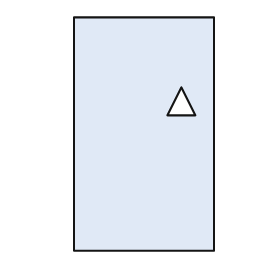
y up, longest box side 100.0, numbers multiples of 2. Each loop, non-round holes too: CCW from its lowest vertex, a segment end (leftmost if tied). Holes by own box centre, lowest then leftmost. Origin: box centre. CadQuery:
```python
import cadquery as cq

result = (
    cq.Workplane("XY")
    .moveTo(-30.0, -50.0)
    .lineTo(30.0, -50.0)
    .lineTo(30.0, 50.0)
    .lineTo(-30.0, 50.0)
    .close()
    .moveTo(10.0, 8.0)
    .lineTo(22.0, 8.0)
    .lineTo(16.0, 20.0)
    .close()
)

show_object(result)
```